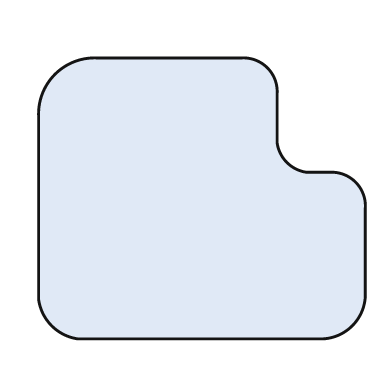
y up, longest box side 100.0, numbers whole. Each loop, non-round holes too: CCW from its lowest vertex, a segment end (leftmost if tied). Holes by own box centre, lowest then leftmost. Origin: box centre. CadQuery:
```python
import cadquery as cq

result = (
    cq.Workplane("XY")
    .moveTo(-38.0, -43.0)
    .lineTo(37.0, -43.0)
    .threePointArc((46.0, -39.0), (50.0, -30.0))
    .lineTo(50.0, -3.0)
    .threePointArc((47.0, 5.0), (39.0, 8.0))
    .lineTo(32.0, 8.0)
    .threePointArc((26.0, 11.0), (23.0, 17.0))
    .lineTo(23.0, 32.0)
    .threePointArc((20.0, 40.0), (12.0, 43.0))
    .lineTo(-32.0, 43.0)
    .threePointArc((-45.0, 38.0), (-50.0, 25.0))
    .lineTo(-50.0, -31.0)
    .threePointArc((-46.0, -39.0), (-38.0, -43.0))
    .close()
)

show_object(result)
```